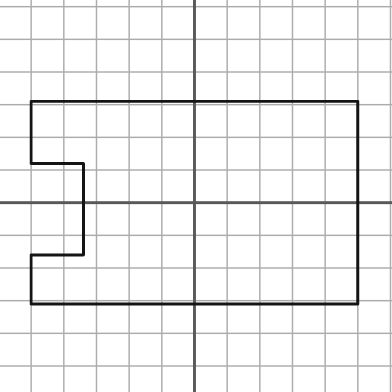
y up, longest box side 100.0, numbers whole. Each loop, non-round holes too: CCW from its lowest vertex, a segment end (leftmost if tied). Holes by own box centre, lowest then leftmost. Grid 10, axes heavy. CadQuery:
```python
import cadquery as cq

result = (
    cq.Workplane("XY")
    .moveTo(-50.0, -31.0)
    .lineTo(50.0, -31.0)
    .lineTo(50.0, 31.0)
    .lineTo(-50.0, 31.0)
    .lineTo(-50.0, 12.0)
    .lineTo(-34.0, 12.0)
    .lineTo(-34.0, -16.0)
    .lineTo(-50.0, -16.0)
    .close()
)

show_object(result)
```